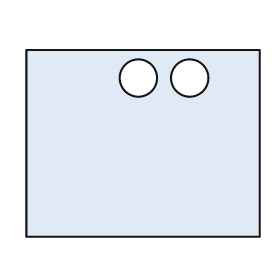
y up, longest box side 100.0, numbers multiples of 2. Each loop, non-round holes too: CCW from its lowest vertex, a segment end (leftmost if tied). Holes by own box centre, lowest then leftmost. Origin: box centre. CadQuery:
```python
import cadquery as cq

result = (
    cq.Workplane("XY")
    .moveTo(-50.0, -40.0)
    .lineTo(50.0, -40.0)
    .lineTo(50.0, 40.0)
    .lineTo(-50.0, 40.0)
    .close()
    .moveTo(-2.0, 28.0)
    .circle(8.0)
    .moveTo(20.0, 28.0)
    .circle(8.0)
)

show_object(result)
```